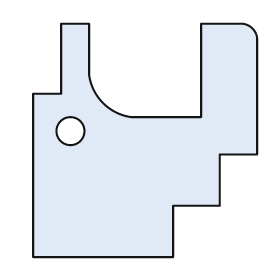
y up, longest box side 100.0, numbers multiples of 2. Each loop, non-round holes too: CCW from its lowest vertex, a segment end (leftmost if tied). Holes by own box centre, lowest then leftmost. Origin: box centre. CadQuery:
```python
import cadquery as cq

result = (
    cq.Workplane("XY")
    .moveTo(-48.0, -50.0)
    .lineTo(12.0, -50.0)
    .lineTo(12.0, -28.0)
    .lineTo(32.0, -28.0)
    .lineTo(32.0, -6.0)
    .lineTo(48.0, -6.0)
    .lineTo(48.0, 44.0)
    .threePointArc((46.0, 48.0), (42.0, 50.0))
    .lineTo(24.0, 50.0)
    .lineTo(24.0, 10.0)
    .lineTo(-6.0, 10.0)
    .threePointArc((-18.0, 16.0), (-24.0, 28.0))
    .lineTo(-24.0, 50.0)
    .lineTo(-36.0, 50.0)
    .lineTo(-36.0, 20.0)
    .lineTo(-48.0, 20.0)
    .close()
    .moveTo(-32.0, 4.0)
    .circle(6.0)
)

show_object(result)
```